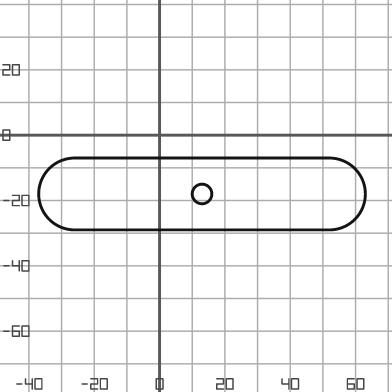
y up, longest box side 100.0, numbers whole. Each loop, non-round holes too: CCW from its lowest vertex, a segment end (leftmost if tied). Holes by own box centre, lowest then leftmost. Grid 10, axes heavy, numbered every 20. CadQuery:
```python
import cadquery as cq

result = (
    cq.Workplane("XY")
    .moveTo(-26.0, -29.0)
    .lineTo(52.0, -29.0)
    .threePointArc((63.0, -18.0), (52.0, -7.0))
    .lineTo(-26.0, -7.0)
    .threePointArc((-37.0, -18.0), (-26.0, -29.0))
    .close()
    .moveTo(13.0, -18.0)
    .circle(3.0)
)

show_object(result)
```